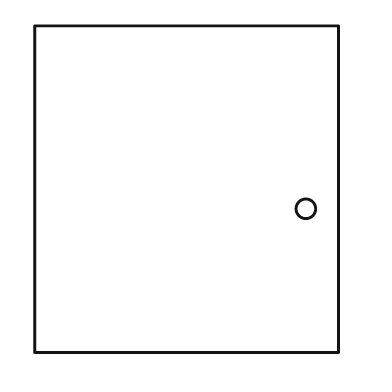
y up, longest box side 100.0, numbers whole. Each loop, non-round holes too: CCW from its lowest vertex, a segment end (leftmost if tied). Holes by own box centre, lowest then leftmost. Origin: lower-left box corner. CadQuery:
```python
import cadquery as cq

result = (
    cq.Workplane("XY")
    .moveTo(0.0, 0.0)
    .lineTo(93.0, 0.0)
    .lineTo(93.0, 100.0)
    .lineTo(0.0, 100.0)
    .close()
    .moveTo(83.0, 44.0)
    .circle(3.0)
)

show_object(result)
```